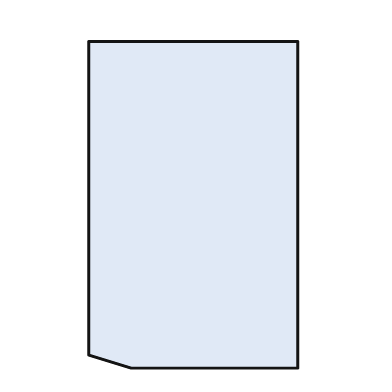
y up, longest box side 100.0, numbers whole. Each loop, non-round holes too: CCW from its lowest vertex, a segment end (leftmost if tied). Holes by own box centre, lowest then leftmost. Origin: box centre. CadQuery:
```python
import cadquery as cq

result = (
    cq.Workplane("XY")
    .moveTo(-19.0, -50.0)
    .lineTo(32.0, -50.0)
    .lineTo(32.0, 50.0)
    .lineTo(-32.0, 50.0)
    .lineTo(-32.0, -46.0)
    .close()
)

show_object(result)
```